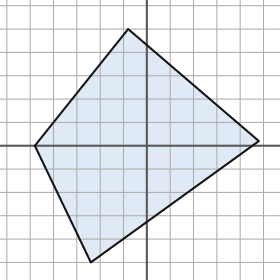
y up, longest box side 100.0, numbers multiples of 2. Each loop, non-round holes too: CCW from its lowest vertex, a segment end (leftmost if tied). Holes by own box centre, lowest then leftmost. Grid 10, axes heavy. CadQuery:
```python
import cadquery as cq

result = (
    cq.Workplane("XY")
    .moveTo(-24.0, -50.0)
    .lineTo(48.0, 2.0)
    .lineTo(-8.0, 50.0)
    .lineTo(-48.0, 0.0)
    .close()
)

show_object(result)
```